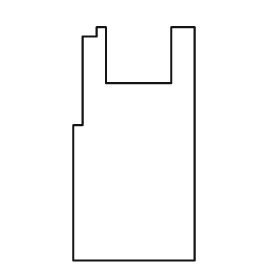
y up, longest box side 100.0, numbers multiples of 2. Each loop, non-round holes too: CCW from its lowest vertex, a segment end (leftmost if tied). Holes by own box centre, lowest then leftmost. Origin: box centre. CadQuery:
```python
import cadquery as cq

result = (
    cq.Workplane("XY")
    .moveTo(-26.0, -50.0)
    .lineTo(26.0, -50.0)
    .lineTo(26.0, 50.0)
    .lineTo(16.0, 50.0)
    .lineTo(16.0, 26.0)
    .lineTo(-12.0, 26.0)
    .lineTo(-12.0, 50.0)
    .lineTo(-16.0, 50.0)
    .lineTo(-16.0, 46.0)
    .lineTo(-22.0, 46.0)
    .lineTo(-22.0, 8.0)
    .lineTo(-26.0, 8.0)
    .close()
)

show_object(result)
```